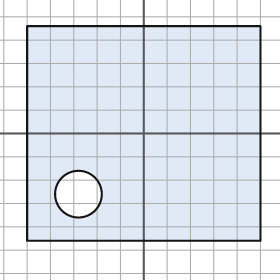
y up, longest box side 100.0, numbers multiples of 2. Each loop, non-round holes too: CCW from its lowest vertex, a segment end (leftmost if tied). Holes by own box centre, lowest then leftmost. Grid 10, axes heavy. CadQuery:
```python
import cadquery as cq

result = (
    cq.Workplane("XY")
    .moveTo(-50.0, -46.0)
    .lineTo(50.0, -46.0)
    .lineTo(50.0, 46.0)
    .lineTo(-50.0, 46.0)
    .close()
    .moveTo(-28.0, -26.0)
    .circle(10.0)
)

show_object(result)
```